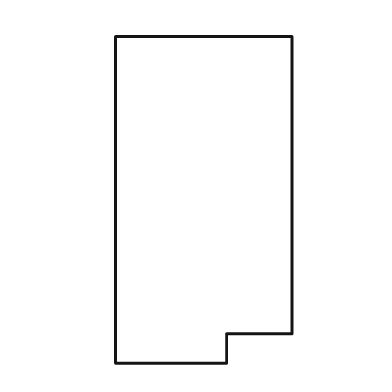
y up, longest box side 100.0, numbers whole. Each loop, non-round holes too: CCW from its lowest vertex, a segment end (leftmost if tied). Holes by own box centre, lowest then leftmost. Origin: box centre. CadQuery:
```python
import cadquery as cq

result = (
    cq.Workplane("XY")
    .moveTo(-27.0, -50.0)
    .lineTo(7.0, -50.0)
    .lineTo(7.0, -41.0)
    .lineTo(27.0, -41.0)
    .lineTo(27.0, 50.0)
    .lineTo(-27.0, 50.0)
    .close()
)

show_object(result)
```